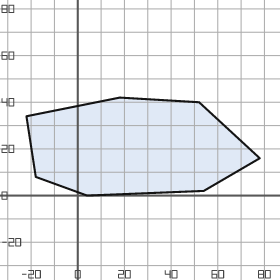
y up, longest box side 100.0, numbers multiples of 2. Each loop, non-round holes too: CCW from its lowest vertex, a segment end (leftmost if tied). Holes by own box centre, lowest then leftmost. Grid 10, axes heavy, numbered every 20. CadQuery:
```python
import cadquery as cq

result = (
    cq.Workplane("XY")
    .moveTo(4.0, 0.0)
    .lineTo(54.0, 2.0)
    .lineTo(78.0, 16.0)
    .lineTo(52.0, 40.0)
    .lineTo(18.0, 42.0)
    .lineTo(-22.0, 34.0)
    .lineTo(-18.0, 8.0)
    .close()
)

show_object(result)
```